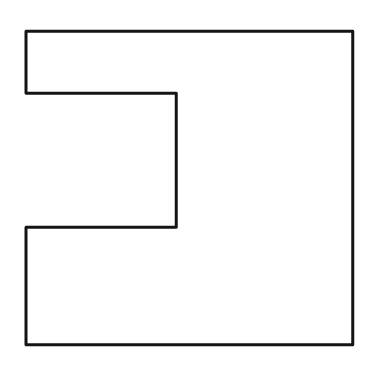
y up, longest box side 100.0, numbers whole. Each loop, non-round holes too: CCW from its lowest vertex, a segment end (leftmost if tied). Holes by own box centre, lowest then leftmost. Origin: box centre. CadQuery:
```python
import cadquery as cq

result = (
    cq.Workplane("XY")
    .moveTo(-50.0, -48.0)
    .lineTo(50.0, -48.0)
    .lineTo(50.0, 48.0)
    .lineTo(-50.0, 48.0)
    .lineTo(-50.0, 29.0)
    .lineTo(-4.0, 29.0)
    .lineTo(-4.0, -12.0)
    .lineTo(-50.0, -12.0)
    .close()
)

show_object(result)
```